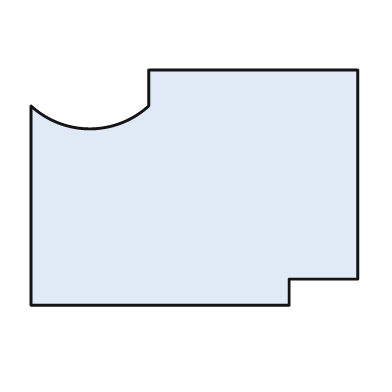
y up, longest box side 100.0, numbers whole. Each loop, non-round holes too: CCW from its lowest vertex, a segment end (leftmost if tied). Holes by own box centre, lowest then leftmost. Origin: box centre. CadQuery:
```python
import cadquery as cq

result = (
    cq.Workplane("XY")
    .moveTo(-50.0, -36.0)
    .lineTo(29.0, -36.0)
    .lineTo(29.0, -28.0)
    .lineTo(50.0, -28.0)
    .lineTo(50.0, 36.0)
    .lineTo(-14.0, 36.0)
    .lineTo(-14.0, 25.0)
    .threePointArc((-32.0, 18.0), (-50.0, 25.0))
    .close()
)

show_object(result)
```